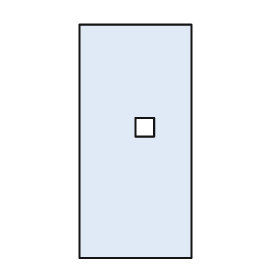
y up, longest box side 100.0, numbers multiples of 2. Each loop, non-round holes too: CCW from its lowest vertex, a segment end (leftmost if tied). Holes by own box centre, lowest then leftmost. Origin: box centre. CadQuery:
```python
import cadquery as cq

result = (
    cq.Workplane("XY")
    .moveTo(-24.0, -50.0)
    .lineTo(24.0, -50.0)
    .lineTo(24.0, 50.0)
    .lineTo(-24.0, 50.0)
    .close()
    .moveTo(0.0, 2.0)
    .lineTo(8.0, 2.0)
    .lineTo(8.0, 10.0)
    .lineTo(0.0, 10.0)
    .close()
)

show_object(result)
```